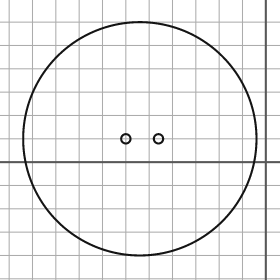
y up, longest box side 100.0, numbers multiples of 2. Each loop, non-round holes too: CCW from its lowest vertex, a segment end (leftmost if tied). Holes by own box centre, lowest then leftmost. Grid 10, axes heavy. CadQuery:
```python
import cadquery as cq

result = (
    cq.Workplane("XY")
    .moveTo(-54.0, 10.0)
    .circle(50.0)
    .moveTo(-60.0, 10.0)
    .circle(2.0)
    .moveTo(-46.0, 10.0)
    .circle(2.0)
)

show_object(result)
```